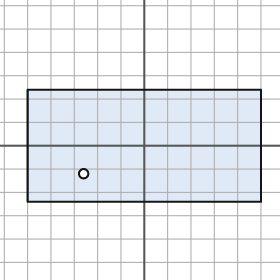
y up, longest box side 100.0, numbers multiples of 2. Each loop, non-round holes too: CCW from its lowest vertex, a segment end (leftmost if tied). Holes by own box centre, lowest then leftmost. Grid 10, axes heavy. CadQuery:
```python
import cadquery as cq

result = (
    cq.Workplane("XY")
    .moveTo(-50.0, -24.0)
    .lineTo(50.0, -24.0)
    .lineTo(50.0, 24.0)
    .lineTo(-50.0, 24.0)
    .close()
    .moveTo(-26.0, -12.0)
    .circle(2.0)
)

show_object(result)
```